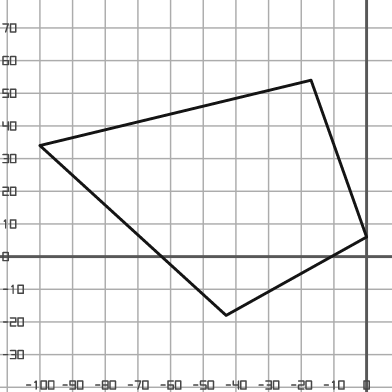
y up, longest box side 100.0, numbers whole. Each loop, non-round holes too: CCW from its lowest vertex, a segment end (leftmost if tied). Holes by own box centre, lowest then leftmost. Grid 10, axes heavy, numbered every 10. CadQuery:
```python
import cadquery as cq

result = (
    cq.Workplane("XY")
    .moveTo(-43.0, -18.0)
    .lineTo(0.0, 6.0)
    .lineTo(-17.0, 54.0)
    .lineTo(-100.0, 34.0)
    .close()
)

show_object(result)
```